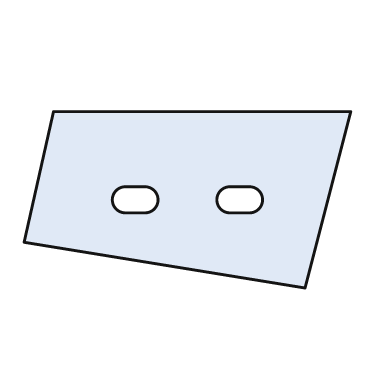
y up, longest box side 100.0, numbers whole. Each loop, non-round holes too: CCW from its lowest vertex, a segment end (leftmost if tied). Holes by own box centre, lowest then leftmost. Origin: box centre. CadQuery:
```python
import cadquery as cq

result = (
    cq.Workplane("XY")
    .moveTo(36.0, -27.0)
    .lineTo(50.0, 27.0)
    .lineTo(-41.0, 27.0)
    .lineTo(-50.0, -13.0)
    .close()
    .moveTo(-19.0, -4.0)
    .lineTo(-13.0, -4.0)
    .threePointArc((-9.0, 0.0), (-13.0, 4.0))
    .lineTo(-19.0, 4.0)
    .threePointArc((-23.0, 0.0), (-19.0, -4.0))
    .close()
    .moveTo(13.0, -4.0)
    .lineTo(19.0, -4.0)
    .threePointArc((23.0, 0.0), (19.0, 4.0))
    .lineTo(13.0, 4.0)
    .threePointArc((9.0, 0.0), (13.0, -4.0))
    .close()
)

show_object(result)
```